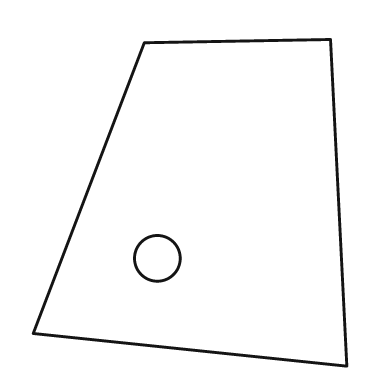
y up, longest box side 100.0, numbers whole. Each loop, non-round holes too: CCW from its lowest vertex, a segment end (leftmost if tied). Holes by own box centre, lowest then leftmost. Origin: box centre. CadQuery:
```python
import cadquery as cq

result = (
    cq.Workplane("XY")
    .moveTo(48.0, -50.0)
    .lineTo(43.0, 50.0)
    .lineTo(-14.0, 49.0)
    .lineTo(-48.0, -40.0)
    .close()
    .moveTo(-10.0, -17.0)
    .circle(7.0)
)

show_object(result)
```